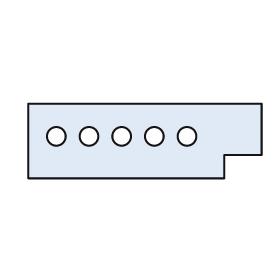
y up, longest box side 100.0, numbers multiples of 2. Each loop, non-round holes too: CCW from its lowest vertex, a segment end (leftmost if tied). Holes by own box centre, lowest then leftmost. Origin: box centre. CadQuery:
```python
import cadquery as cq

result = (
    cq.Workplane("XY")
    .moveTo(-50.0, -16.0)
    .lineTo(34.0, -16.0)
    .lineTo(34.0, -6.0)
    .lineTo(50.0, -6.0)
    .lineTo(50.0, 16.0)
    .lineTo(-50.0, 16.0)
    .close()
    .moveTo(-38.0, 2.0)
    .circle(4.0)
    .moveTo(-24.0, 2.0)
    .circle(4.0)
    .moveTo(-10.0, 2.0)
    .circle(4.0)
    .moveTo(4.0, 2.0)
    .circle(4.0)
    .moveTo(18.0, 2.0)
    .circle(4.0)
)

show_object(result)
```